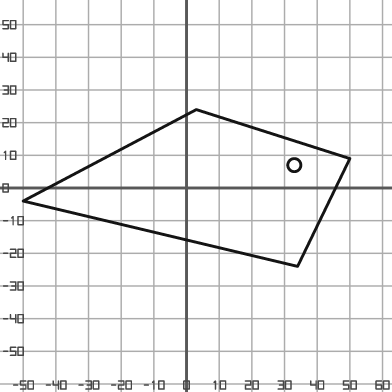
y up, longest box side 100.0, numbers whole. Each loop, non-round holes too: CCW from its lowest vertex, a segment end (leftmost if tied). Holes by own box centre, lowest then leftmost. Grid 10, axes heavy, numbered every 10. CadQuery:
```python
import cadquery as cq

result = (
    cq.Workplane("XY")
    .moveTo(34.0, -24.0)
    .lineTo(50.0, 9.0)
    .lineTo(3.0, 24.0)
    .lineTo(-50.0, -4.0)
    .close()
    .moveTo(33.0, 7.0)
    .circle(2.0)
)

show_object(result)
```